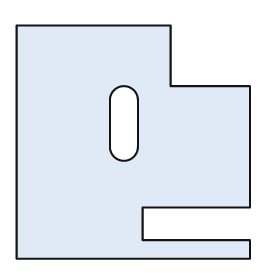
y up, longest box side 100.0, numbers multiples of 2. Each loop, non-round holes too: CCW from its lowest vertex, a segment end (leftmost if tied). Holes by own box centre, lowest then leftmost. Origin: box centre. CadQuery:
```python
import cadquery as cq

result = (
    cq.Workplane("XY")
    .moveTo(-50.0, -50.0)
    .lineTo(50.0, -50.0)
    .lineTo(50.0, -42.0)
    .lineTo(4.0, -42.0)
    .lineTo(4.0, -28.0)
    .lineTo(50.0, -28.0)
    .lineTo(50.0, 24.0)
    .lineTo(16.0, 24.0)
    .lineTo(16.0, 50.0)
    .lineTo(-50.0, 50.0)
    .close()
    .moveTo(-10.0, -2.0)
    .threePointArc((-4.0, -8.0), (2.0, -2.0))
    .lineTo(2.0, 18.0)
    .threePointArc((-4.0, 24.0), (-10.0, 18.0))
    .close()
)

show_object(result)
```